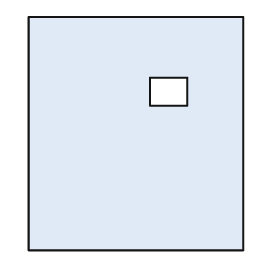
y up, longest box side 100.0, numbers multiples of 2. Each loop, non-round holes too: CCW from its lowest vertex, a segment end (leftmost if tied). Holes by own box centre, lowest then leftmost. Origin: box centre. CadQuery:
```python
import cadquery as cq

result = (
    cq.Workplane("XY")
    .moveTo(-46.0, -50.0)
    .lineTo(46.0, -50.0)
    .lineTo(46.0, 50.0)
    .lineTo(-46.0, 50.0)
    .close()
    .moveTo(6.0, 12.0)
    .lineTo(22.0, 12.0)
    .lineTo(22.0, 24.0)
    .lineTo(6.0, 24.0)
    .close()
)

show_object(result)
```